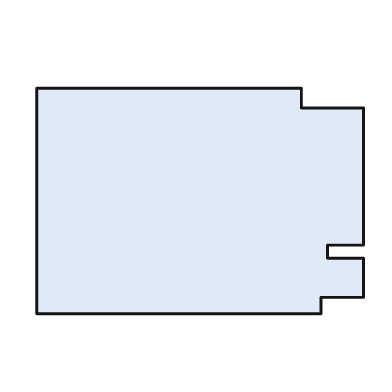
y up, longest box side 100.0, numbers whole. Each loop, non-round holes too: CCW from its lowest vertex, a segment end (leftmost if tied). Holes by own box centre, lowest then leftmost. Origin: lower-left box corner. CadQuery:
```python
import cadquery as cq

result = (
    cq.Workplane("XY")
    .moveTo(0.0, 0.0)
    .lineTo(87.0, 0.0)
    .lineTo(87.0, 5.0)
    .lineTo(100.0, 5.0)
    .lineTo(100.0, 17.0)
    .lineTo(89.0, 17.0)
    .lineTo(89.0, 21.0)
    .lineTo(100.0, 21.0)
    .lineTo(100.0, 63.0)
    .lineTo(81.0, 63.0)
    .lineTo(81.0, 69.0)
    .lineTo(0.0, 69.0)
    .close()
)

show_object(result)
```